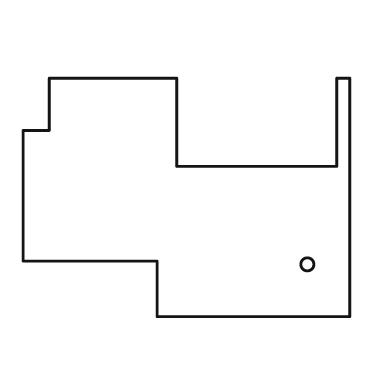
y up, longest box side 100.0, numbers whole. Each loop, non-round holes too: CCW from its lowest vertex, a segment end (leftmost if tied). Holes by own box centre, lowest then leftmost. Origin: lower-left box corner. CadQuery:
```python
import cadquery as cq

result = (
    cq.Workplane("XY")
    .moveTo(41.0, 0.0)
    .lineTo(100.0, 0.0)
    .lineTo(100.0, 73.0)
    .lineTo(96.0, 73.0)
    .lineTo(96.0, 46.0)
    .lineTo(47.0, 46.0)
    .lineTo(47.0, 73.0)
    .lineTo(8.0, 73.0)
    .lineTo(8.0, 57.0)
    .lineTo(0.0, 57.0)
    .lineTo(0.0, 17.0)
    .lineTo(41.0, 17.0)
    .close()
    .moveTo(87.0, 16.0)
    .circle(2.0)
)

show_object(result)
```